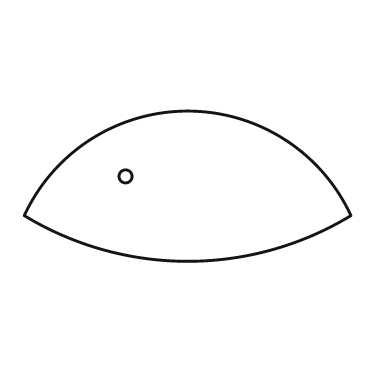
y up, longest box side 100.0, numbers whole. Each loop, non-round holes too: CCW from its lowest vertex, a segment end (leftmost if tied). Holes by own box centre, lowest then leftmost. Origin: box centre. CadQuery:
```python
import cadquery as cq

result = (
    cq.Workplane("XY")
    .moveTo(-50.0, -9.0)
    .threePointArc((0.0, -23.0), (50.0, -9.0))
    .threePointArc((0.0, 23.0), (-50.0, -9.0))
    .close()
    .moveTo(-19.0, 3.0)
    .circle(2.0)
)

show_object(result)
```